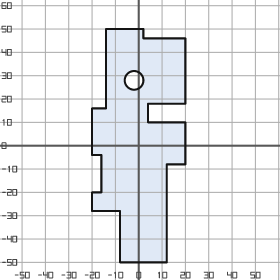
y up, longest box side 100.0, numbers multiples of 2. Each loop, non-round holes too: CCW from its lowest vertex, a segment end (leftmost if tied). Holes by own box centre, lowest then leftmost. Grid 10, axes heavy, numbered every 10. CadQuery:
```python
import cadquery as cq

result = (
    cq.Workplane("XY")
    .moveTo(-8.0, -50.0)
    .lineTo(12.0, -50.0)
    .lineTo(12.0, -8.0)
    .lineTo(20.0, -8.0)
    .lineTo(20.0, 10.0)
    .lineTo(4.0, 10.0)
    .lineTo(4.0, 18.0)
    .lineTo(20.0, 18.0)
    .lineTo(20.0, 46.0)
    .lineTo(2.0, 46.0)
    .lineTo(2.0, 50.0)
    .lineTo(-14.0, 50.0)
    .lineTo(-14.0, 16.0)
    .lineTo(-20.0, 16.0)
    .lineTo(-20.0, -4.0)
    .lineTo(-16.0, -4.0)
    .lineTo(-16.0, -20.0)
    .lineTo(-20.0, -20.0)
    .lineTo(-20.0, -28.0)
    .lineTo(-8.0, -28.0)
    .close()
    .moveTo(-2.0, 28.0)
    .circle(4.0)
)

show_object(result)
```